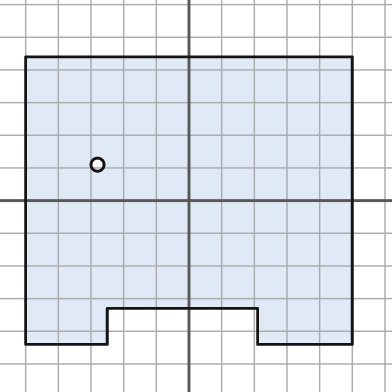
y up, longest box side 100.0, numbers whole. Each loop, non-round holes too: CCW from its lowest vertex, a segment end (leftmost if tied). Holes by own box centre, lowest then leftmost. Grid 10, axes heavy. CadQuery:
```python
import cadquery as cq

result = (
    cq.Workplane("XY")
    .moveTo(-50.0, -44.0)
    .lineTo(-25.0, -44.0)
    .lineTo(-25.0, -33.0)
    .lineTo(21.0, -33.0)
    .lineTo(21.0, -44.0)
    .lineTo(50.0, -44.0)
    .lineTo(50.0, 44.0)
    .lineTo(-50.0, 44.0)
    .close()
    .moveTo(-28.0, 11.0)
    .circle(2.0)
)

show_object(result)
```